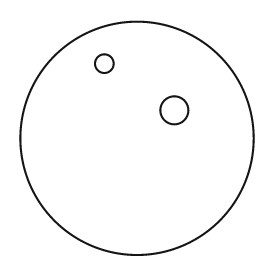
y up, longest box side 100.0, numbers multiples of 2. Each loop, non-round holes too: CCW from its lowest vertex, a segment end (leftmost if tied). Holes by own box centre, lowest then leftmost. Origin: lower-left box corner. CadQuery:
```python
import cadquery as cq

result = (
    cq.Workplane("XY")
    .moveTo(50.0, 50.0)
    .circle(50.0)
    .moveTo(66.0, 62.0)
    .circle(6.0)
    .moveTo(36.0, 82.0)
    .circle(4.0)
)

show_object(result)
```